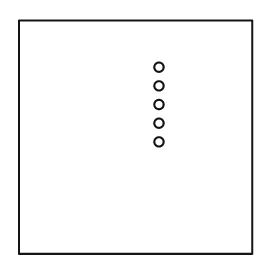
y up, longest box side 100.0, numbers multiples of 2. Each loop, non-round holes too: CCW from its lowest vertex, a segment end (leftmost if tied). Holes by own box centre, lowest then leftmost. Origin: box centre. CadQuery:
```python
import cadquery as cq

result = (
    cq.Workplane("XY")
    .moveTo(-50.0, -50.0)
    .lineTo(50.0, -50.0)
    .lineTo(50.0, 50.0)
    .lineTo(-50.0, 50.0)
    .close()
    .moveTo(10.0, -2.0)
    .circle(2.0)
    .moveTo(10.0, 6.0)
    .circle(2.0)
    .moveTo(10.0, 14.0)
    .circle(2.0)
    .moveTo(10.0, 22.0)
    .circle(2.0)
    .moveTo(10.0, 30.0)
    .circle(2.0)
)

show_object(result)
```